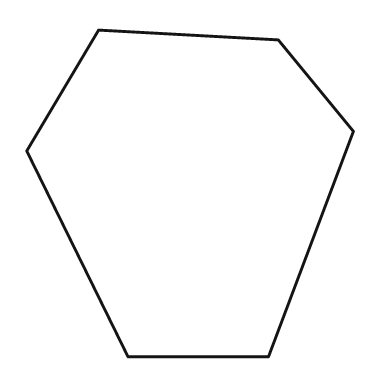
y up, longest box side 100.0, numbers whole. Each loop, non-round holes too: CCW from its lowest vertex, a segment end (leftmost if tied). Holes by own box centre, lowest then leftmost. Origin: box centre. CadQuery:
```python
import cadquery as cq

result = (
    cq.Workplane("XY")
    .moveTo(-19.0, -50.0)
    .lineTo(24.0, -50.0)
    .lineTo(50.0, 19.0)
    .lineTo(27.0, 47.0)
    .lineTo(-28.0, 50.0)
    .lineTo(-50.0, 13.0)
    .close()
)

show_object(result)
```